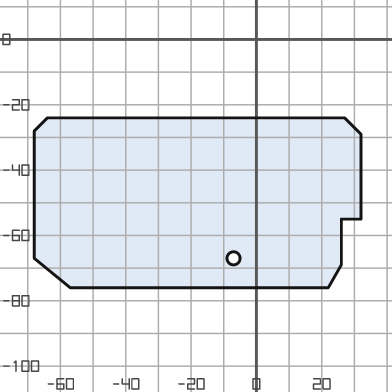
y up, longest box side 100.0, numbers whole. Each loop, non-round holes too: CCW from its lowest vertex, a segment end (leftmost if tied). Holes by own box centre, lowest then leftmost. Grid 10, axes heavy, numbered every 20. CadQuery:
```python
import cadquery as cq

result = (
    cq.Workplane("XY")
    .moveTo(-57.0, -76.0)
    .lineTo(22.0, -76.0)
    .lineTo(26.0, -69.0)
    .lineTo(26.0, -55.0)
    .lineTo(32.0, -55.0)
    .lineTo(32.0, -29.0)
    .lineTo(27.0, -24.0)
    .lineTo(-64.0, -24.0)
    .lineTo(-68.0, -28.0)
    .lineTo(-68.0, -67.0)
    .close()
    .moveTo(-7.0, -67.0)
    .circle(2.0)
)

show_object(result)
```